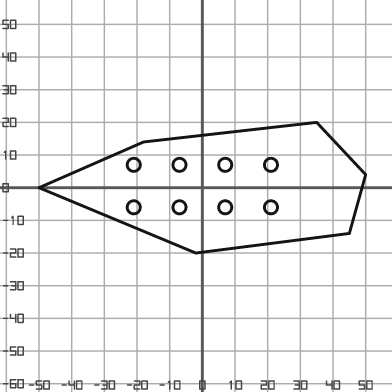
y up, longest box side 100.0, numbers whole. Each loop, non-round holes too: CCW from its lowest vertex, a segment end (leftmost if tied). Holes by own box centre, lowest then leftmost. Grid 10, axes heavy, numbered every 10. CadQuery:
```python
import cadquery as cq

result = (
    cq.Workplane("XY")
    .moveTo(-2.0, -20.0)
    .lineTo(45.0, -14.0)
    .lineTo(50.0, 4.0)
    .lineTo(35.0, 20.0)
    .lineTo(-18.0, 14.0)
    .lineTo(-50.0, 0.0)
    .close()
    .moveTo(-21.0, -6.0)
    .circle(2.0)
    .moveTo(-7.0, -6.0)
    .circle(2.0)
    .moveTo(7.0, -6.0)
    .circle(2.0)
    .moveTo(21.0, -6.0)
    .circle(2.0)
    .moveTo(-21.0, 7.0)
    .circle(2.0)
    .moveTo(-7.0, 7.0)
    .circle(2.0)
    .moveTo(7.0, 7.0)
    .circle(2.0)
    .moveTo(21.0, 7.0)
    .circle(2.0)
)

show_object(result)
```